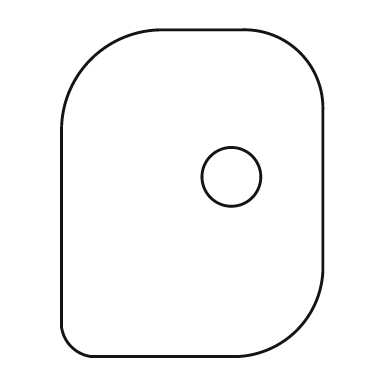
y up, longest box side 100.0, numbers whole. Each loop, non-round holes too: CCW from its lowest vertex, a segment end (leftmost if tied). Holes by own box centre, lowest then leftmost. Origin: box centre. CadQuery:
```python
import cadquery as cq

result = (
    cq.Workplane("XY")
    .moveTo(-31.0, -50.0)
    .lineTo(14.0, -50.0)
    .threePointArc((32.0, -42.0), (40.0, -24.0))
    .lineTo(40.0, 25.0)
    .threePointArc((33.0, 43.0), (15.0, 50.0))
    .lineTo(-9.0, 50.0)
    .threePointArc((-31.0, 41.0), (-40.0, 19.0))
    .lineTo(-40.0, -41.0)
    .threePointArc((-37.0, -47.0), (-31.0, -50.0))
    .close()
    .moveTo(12.0, 5.0)
    .circle(9.0)
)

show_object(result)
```